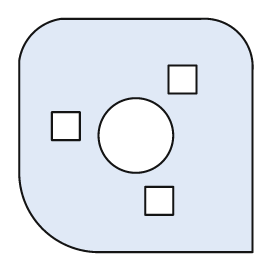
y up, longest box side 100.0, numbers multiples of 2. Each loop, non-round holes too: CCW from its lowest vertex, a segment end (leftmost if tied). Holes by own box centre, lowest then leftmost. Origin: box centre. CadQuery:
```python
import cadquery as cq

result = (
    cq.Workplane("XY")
    .moveTo(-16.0, -50.0)
    .lineTo(50.0, -50.0)
    .lineTo(50.0, 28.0)
    .threePointArc((44.0, 44.0), (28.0, 50.0))
    .lineTo(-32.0, 50.0)
    .threePointArc((-44.0, 44.0), (-50.0, 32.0))
    .lineTo(-50.0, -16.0)
    .threePointArc((-40.0, -40.0), (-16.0, -50.0))
    .close()
    .moveTo(4.0, -34.0)
    .lineTo(16.0, -34.0)
    .lineTo(16.0, -22.0)
    .lineTo(4.0, -22.0)
    .close()
    .moveTo(0.0, 0.0)
    .circle(16.0)
    .moveTo(-36.0, -2.0)
    .lineTo(-24.0, -2.0)
    .lineTo(-24.0, 10.0)
    .lineTo(-36.0, 10.0)
    .close()
    .moveTo(14.0, 18.0)
    .lineTo(26.0, 18.0)
    .lineTo(26.0, 30.0)
    .lineTo(14.0, 30.0)
    .close()
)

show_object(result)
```